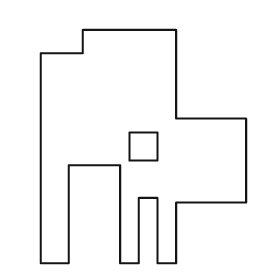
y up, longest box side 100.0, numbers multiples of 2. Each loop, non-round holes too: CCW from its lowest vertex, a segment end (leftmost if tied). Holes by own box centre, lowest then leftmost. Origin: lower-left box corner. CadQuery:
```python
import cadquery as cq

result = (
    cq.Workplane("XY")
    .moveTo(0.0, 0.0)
    .lineTo(12.0, 0.0)
    .lineTo(12.0, 42.0)
    .lineTo(34.0, 42.0)
    .lineTo(34.0, 0.0)
    .lineTo(42.0, 0.0)
    .lineTo(42.0, 28.0)
    .lineTo(50.0, 28.0)
    .lineTo(50.0, 0.0)
    .lineTo(58.0, 0.0)
    .lineTo(58.0, 26.0)
    .lineTo(88.0, 26.0)
    .lineTo(88.0, 62.0)
    .lineTo(58.0, 62.0)
    .lineTo(58.0, 100.0)
    .lineTo(18.0, 100.0)
    .lineTo(18.0, 90.0)
    .lineTo(0.0, 90.0)
    .close()
    .moveTo(38.0, 44.0)
    .lineTo(50.0, 44.0)
    .lineTo(50.0, 56.0)
    .lineTo(38.0, 56.0)
    .close()
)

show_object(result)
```